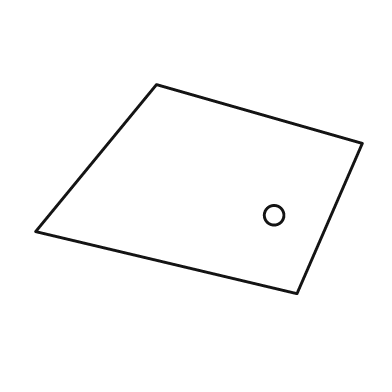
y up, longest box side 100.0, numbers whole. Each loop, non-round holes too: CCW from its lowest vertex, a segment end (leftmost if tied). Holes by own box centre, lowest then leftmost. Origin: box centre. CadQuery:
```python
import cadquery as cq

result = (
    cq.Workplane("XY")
    .moveTo(30.0, -32.0)
    .lineTo(50.0, 14.0)
    .lineTo(-13.0, 32.0)
    .lineTo(-50.0, -13.0)
    .close()
    .moveTo(23.0, -8.0)
    .circle(3.0)
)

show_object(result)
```